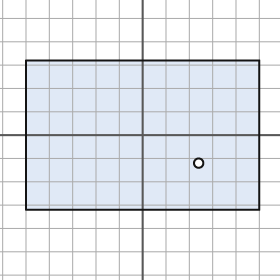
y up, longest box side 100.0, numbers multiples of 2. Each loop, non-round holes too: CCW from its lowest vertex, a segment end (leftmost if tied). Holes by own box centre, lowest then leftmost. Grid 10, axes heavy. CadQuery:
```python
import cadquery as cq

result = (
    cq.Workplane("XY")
    .moveTo(-50.0, -32.0)
    .lineTo(50.0, -32.0)
    .lineTo(50.0, 32.0)
    .lineTo(-50.0, 32.0)
    .close()
    .moveTo(24.0, -12.0)
    .circle(2.0)
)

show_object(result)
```